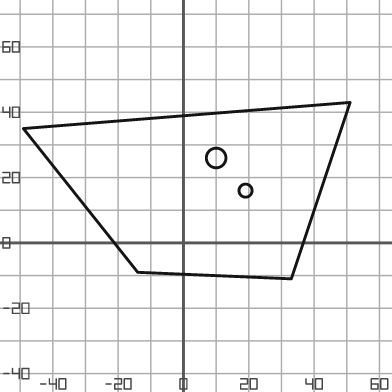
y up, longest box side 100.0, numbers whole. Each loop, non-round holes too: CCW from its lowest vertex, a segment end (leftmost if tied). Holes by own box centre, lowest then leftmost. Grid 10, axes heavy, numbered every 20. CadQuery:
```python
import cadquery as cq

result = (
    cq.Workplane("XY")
    .moveTo(33.0, -11.0)
    .lineTo(51.0, 43.0)
    .lineTo(-49.0, 35.0)
    .lineTo(-14.0, -9.0)
    .close()
    .moveTo(19.0, 16.0)
    .circle(2.0)
    .moveTo(10.0, 26.0)
    .circle(3.0)
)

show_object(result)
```